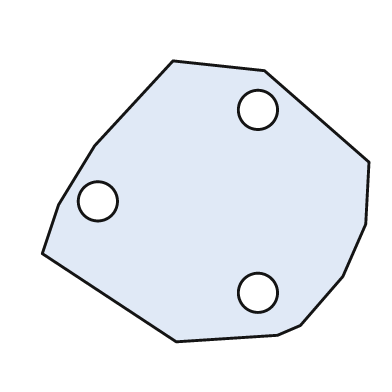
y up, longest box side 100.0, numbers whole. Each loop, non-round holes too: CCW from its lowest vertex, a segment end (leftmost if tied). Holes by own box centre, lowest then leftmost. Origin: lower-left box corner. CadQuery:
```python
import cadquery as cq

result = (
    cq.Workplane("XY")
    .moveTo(41.0, 0.0)
    .lineTo(72.0, 2.0)
    .lineTo(79.0, 5.0)
    .lineTo(92.0, 20.0)
    .lineTo(99.0, 36.0)
    .lineTo(100.0, 55.0)
    .lineTo(68.0, 83.0)
    .lineTo(40.0, 86.0)
    .lineTo(16.0, 60.0)
    .lineTo(5.0, 42.0)
    .lineTo(0.0, 27.0)
    .close()
    .moveTo(66.0, 15.0)
    .circle(6.0)
    .moveTo(17.0, 43.0)
    .circle(6.0)
    .moveTo(66.0, 71.0)
    .circle(6.0)
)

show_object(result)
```